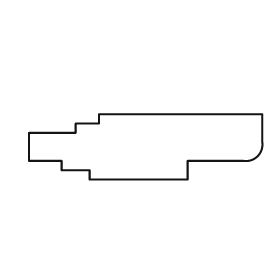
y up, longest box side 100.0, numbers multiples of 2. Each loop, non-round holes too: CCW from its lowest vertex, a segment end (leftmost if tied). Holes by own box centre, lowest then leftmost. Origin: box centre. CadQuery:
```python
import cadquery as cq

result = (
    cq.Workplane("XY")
    .moveTo(-24.0, -14.0)
    .lineTo(18.0, -14.0)
    .lineTo(18.0, -6.0)
    .lineTo(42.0, -6.0)
    .threePointArc((48.0, -4.0), (50.0, 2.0))
    .lineTo(50.0, 14.0)
    .lineTo(-20.0, 14.0)
    .lineTo(-20.0, 10.0)
    .lineTo(-30.0, 10.0)
    .lineTo(-30.0, 6.0)
    .lineTo(-50.0, 6.0)
    .lineTo(-50.0, -6.0)
    .lineTo(-36.0, -6.0)
    .lineTo(-36.0, -10.0)
    .lineTo(-24.0, -10.0)
    .close()
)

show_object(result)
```